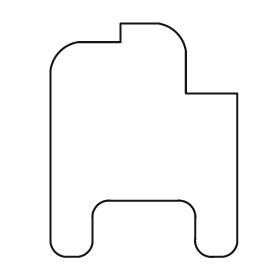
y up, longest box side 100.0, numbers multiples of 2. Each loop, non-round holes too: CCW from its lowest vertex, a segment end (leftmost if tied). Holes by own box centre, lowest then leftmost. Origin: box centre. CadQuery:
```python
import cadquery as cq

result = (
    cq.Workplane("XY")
    .moveTo(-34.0, -50.0)
    .lineTo(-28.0, -50.0)
    .threePointArc((-24.0, -48.0), (-22.0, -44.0))
    .lineTo(-22.0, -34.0)
    .threePointArc((-20.0, -28.0), (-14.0, -26.0))
    .lineTo(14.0, -26.0)
    .threePointArc((20.0, -28.0), (22.0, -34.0))
    .lineTo(22.0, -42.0)
    .threePointArc((24.0, -48.0), (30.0, -50.0))
    .lineTo(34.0, -50.0)
    .threePointArc((38.0, -48.0), (40.0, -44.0))
    .lineTo(40.0, 20.0)
    .lineTo(18.0, 20.0)
    .lineTo(18.0, 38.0)
    .threePointArc((14.0, 46.0), (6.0, 50.0))
    .lineTo(-10.0, 50.0)
    .lineTo(-10.0, 42.0)
    .lineTo(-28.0, 42.0)
    .threePointArc((-36.0, 38.0), (-40.0, 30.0))
    .lineTo(-40.0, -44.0)
    .threePointArc((-38.0, -48.0), (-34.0, -50.0))
    .close()
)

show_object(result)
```